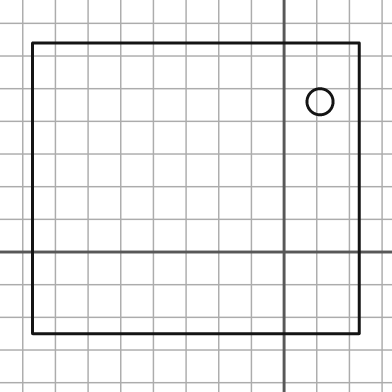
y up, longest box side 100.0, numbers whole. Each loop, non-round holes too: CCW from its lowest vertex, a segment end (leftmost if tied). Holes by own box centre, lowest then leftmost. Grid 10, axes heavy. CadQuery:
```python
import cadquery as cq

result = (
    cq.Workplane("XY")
    .moveTo(-77.0, -25.0)
    .lineTo(23.0, -25.0)
    .lineTo(23.0, 64.0)
    .lineTo(-77.0, 64.0)
    .close()
    .moveTo(11.0, 46.0)
    .circle(4.0)
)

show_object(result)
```